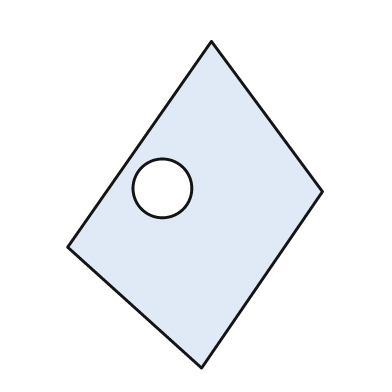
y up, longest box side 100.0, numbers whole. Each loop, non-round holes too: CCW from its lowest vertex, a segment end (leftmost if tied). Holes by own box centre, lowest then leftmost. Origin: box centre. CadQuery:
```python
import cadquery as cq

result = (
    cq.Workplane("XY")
    .moveTo(2.0, -50.0)
    .lineTo(39.0, 4.0)
    .lineTo(5.0, 50.0)
    .lineTo(-39.0, -13.0)
    .close()
    .moveTo(-10.0, 5.0)
    .circle(9.0)
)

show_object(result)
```